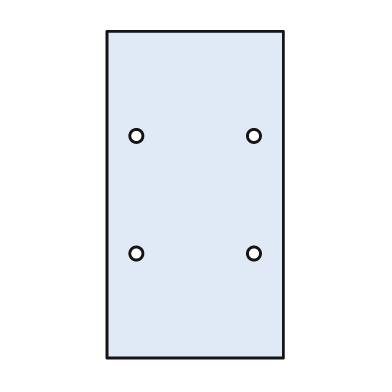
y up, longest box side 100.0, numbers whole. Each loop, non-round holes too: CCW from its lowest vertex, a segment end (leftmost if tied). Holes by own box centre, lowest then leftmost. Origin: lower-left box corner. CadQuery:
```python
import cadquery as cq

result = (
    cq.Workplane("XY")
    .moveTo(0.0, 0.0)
    .lineTo(54.0, 0.0)
    .lineTo(54.0, 100.0)
    .lineTo(0.0, 100.0)
    .close()
    .moveTo(9.0, 32.0)
    .circle(2.0)
    .moveTo(45.0, 32.0)
    .circle(2.0)
    .moveTo(9.0, 68.0)
    .circle(2.0)
    .moveTo(45.0, 68.0)
    .circle(2.0)
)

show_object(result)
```